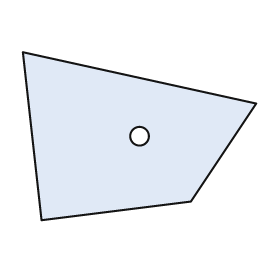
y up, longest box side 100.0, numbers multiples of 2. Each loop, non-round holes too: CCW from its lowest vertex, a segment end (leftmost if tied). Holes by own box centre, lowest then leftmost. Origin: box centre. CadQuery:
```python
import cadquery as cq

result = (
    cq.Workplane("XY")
    .moveTo(-42.0, -36.0)
    .lineTo(22.0, -28.0)
    .lineTo(50.0, 14.0)
    .lineTo(-50.0, 36.0)
    .close()
    .moveTo(0.0, 0.0)
    .circle(4.0)
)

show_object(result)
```